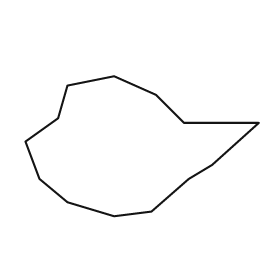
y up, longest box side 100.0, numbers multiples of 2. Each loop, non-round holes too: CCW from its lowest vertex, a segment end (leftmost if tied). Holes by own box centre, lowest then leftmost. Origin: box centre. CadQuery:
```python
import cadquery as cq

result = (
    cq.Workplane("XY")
    .moveTo(-12.0, -30.0)
    .lineTo(4.0, -28.0)
    .lineTo(20.0, -14.0)
    .lineTo(30.0, -8.0)
    .lineTo(50.0, 10.0)
    .lineTo(18.0, 10.0)
    .lineTo(6.0, 22.0)
    .lineTo(-12.0, 30.0)
    .lineTo(-32.0, 26.0)
    .lineTo(-36.0, 12.0)
    .lineTo(-50.0, 2.0)
    .lineTo(-44.0, -14.0)
    .lineTo(-32.0, -24.0)
    .close()
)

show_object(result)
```